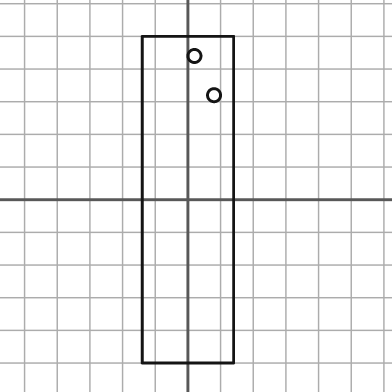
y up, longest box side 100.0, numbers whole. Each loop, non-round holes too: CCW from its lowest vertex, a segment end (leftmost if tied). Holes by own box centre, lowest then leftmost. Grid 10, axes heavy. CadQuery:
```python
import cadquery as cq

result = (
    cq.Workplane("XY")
    .moveTo(-14.0, -50.0)
    .lineTo(14.0, -50.0)
    .lineTo(14.0, 50.0)
    .lineTo(-14.0, 50.0)
    .close()
    .moveTo(8.0, 32.0)
    .circle(2.0)
    .moveTo(2.0, 44.0)
    .circle(2.0)
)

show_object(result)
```